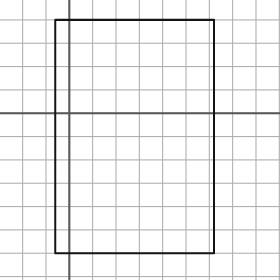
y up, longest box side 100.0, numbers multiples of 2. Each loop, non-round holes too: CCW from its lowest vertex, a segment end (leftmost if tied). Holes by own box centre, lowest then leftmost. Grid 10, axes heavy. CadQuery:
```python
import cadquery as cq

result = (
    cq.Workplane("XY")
    .moveTo(-6.0, -60.0)
    .lineTo(62.0, -60.0)
    .lineTo(62.0, 40.0)
    .lineTo(-6.0, 40.0)
    .close()
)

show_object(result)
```